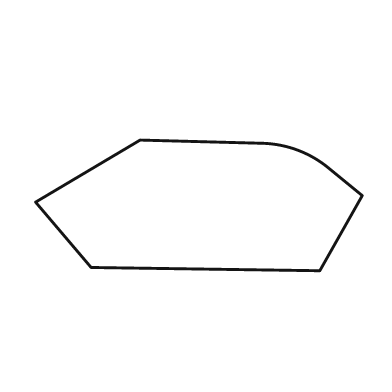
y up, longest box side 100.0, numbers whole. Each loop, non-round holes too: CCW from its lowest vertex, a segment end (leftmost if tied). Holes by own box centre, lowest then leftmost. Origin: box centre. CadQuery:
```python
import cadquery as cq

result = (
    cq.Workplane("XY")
    .moveTo(37.0, -20.0)
    .lineTo(50.0, 3.0)
    .lineTo(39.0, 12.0)
    .threePointArc((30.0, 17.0), (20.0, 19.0))
    .lineTo(-18.0, 20.0)
    .lineTo(-50.0, 1.0)
    .lineTo(-33.0, -19.0)
    .close()
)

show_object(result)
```